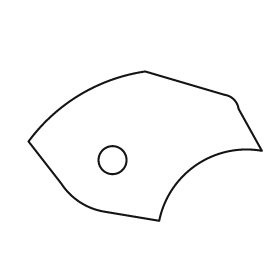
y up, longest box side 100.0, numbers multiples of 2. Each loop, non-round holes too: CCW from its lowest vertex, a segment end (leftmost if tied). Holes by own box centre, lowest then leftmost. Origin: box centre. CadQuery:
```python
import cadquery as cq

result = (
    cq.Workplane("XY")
    .moveTo(6.0, -32.0)
    .threePointArc((22.0, -8.0), (50.0, -2.0))
    .lineTo(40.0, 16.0)
    .threePointArc((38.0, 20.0), (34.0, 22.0))
    .lineTo(0.0, 32.0)
    .threePointArc((-28.0, 22.0), (-50.0, 2.0))
    .lineTo(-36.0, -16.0)
    .threePointArc((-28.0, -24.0), (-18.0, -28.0))
    .close()
    .moveTo(-14.0, -6.0)
    .circle(6.0)
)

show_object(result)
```